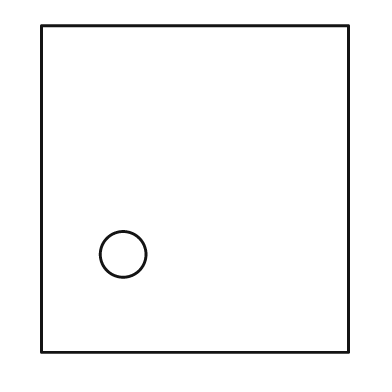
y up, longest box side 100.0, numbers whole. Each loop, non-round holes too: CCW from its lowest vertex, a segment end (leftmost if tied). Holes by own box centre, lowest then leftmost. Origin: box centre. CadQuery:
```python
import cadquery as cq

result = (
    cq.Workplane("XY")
    .moveTo(-47.0, -50.0)
    .lineTo(47.0, -50.0)
    .lineTo(47.0, 50.0)
    .lineTo(-47.0, 50.0)
    .close()
    .moveTo(-22.0, -20.0)
    .circle(7.0)
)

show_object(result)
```